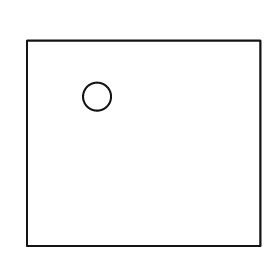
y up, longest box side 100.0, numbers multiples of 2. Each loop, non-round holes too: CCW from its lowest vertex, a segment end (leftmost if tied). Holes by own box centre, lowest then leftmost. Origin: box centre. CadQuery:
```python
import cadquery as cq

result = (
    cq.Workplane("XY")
    .moveTo(-50.0, -44.0)
    .lineTo(50.0, -44.0)
    .lineTo(50.0, 44.0)
    .lineTo(-50.0, 44.0)
    .close()
    .moveTo(-20.0, 20.0)
    .circle(6.0)
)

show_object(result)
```